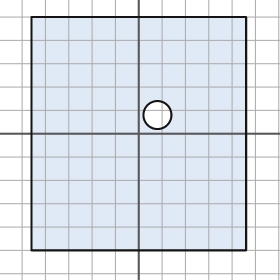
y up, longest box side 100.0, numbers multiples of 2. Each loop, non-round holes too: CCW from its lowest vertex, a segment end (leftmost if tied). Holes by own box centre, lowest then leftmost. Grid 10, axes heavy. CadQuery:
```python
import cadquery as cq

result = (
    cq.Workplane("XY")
    .moveTo(-46.0, -50.0)
    .lineTo(46.0, -50.0)
    .lineTo(46.0, 50.0)
    .lineTo(-46.0, 50.0)
    .close()
    .moveTo(8.0, 8.0)
    .circle(6.0)
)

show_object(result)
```